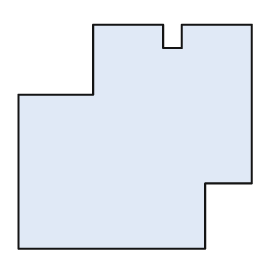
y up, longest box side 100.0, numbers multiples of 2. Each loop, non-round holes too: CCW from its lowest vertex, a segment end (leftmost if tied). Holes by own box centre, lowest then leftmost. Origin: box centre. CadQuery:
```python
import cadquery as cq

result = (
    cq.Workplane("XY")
    .moveTo(-50.0, -48.0)
    .lineTo(30.0, -48.0)
    .lineTo(30.0, -20.0)
    .lineTo(50.0, -20.0)
    .lineTo(50.0, 48.0)
    .lineTo(20.0, 48.0)
    .lineTo(20.0, 38.0)
    .lineTo(12.0, 38.0)
    .lineTo(12.0, 48.0)
    .lineTo(-18.0, 48.0)
    .lineTo(-18.0, 18.0)
    .lineTo(-50.0, 18.0)
    .close()
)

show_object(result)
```